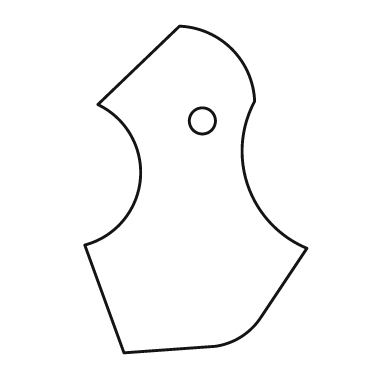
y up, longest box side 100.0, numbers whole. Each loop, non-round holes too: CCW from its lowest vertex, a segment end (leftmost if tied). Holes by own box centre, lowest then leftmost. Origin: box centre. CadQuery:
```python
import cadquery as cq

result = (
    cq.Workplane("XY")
    .moveTo(-22.0, -50.0)
    .lineTo(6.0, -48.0)
    .threePointArc((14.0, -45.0), (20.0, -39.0))
    .lineTo(34.0, -18.0)
    .threePointArc((16.0, 1.0), (18.0, 27.0))
    .threePointArc((11.0, 43.0), (-5.0, 50.0))
    .lineTo(-30.0, 26.0)
    .threePointArc((-17.0, 3.0), (-34.0, -17.0))
    .close()
    .moveTo(2.0, 21.0)
    .circle(4.0)
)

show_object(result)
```